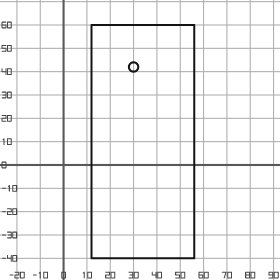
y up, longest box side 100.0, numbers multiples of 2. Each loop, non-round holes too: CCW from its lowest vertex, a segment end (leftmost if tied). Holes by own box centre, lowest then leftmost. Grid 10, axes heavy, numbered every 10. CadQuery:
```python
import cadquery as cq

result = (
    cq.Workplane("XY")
    .moveTo(12.0, -40.0)
    .lineTo(56.0, -40.0)
    .lineTo(56.0, 60.0)
    .lineTo(12.0, 60.0)
    .close()
    .moveTo(30.0, 42.0)
    .circle(2.0)
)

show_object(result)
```